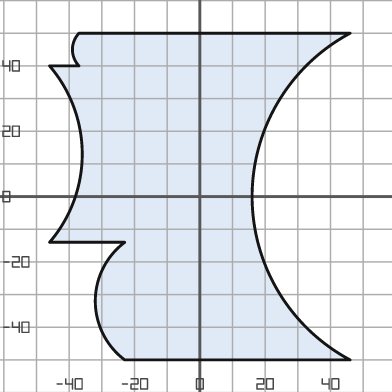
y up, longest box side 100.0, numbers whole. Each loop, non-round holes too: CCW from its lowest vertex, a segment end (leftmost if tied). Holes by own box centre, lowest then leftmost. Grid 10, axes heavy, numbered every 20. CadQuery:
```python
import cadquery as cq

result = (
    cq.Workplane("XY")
    .moveTo(-23.0, -50.0)
    .lineTo(46.0, -50.0)
    .threePointArc((16.0, 0.0), (46.0, 50.0))
    .lineTo(-37.0, 50.0)
    .threePointArc((-39.0, 45.0), (-37.0, 40.0))
    .lineTo(-46.0, 40.0)
    .threePointArc((-36.0, 13.0), (-46.0, -14.0))
    .lineTo(-23.0, -14.0)
    .threePointArc((-32.0, -32.0), (-23.0, -50.0))
    .close()
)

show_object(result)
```